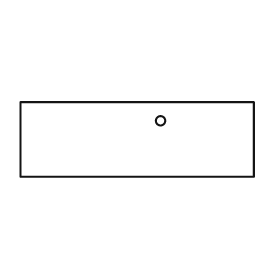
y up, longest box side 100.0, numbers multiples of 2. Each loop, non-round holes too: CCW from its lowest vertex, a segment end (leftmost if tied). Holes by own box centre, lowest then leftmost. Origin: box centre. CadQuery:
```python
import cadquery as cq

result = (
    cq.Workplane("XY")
    .moveTo(-50.0, -16.0)
    .lineTo(50.0, -16.0)
    .lineTo(50.0, 16.0)
    .lineTo(-50.0, 16.0)
    .close()
    .moveTo(10.0, 8.0)
    .circle(2.0)
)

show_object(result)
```